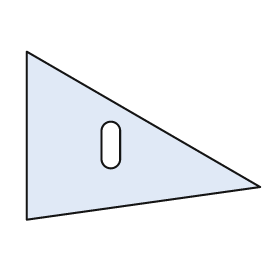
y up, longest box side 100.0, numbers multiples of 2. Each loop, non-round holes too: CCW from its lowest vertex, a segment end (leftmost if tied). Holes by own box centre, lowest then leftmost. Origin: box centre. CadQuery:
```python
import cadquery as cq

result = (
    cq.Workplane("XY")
    .moveTo(-50.0, -36.0)
    .lineTo(50.0, -22.0)
    .lineTo(-50.0, 36.0)
    .close()
    .moveTo(-18.0, -10.0)
    .threePointArc((-14.0, -14.0), (-10.0, -10.0))
    .lineTo(-10.0, 2.0)
    .threePointArc((-14.0, 6.0), (-18.0, 2.0))
    .close()
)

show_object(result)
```